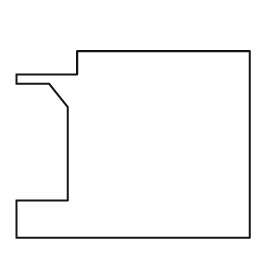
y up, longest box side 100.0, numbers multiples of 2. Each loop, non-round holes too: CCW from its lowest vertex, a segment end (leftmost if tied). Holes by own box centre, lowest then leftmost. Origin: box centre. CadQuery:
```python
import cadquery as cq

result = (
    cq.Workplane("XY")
    .moveTo(-50.0, -40.0)
    .lineTo(50.0, -40.0)
    .lineTo(50.0, 40.0)
    .lineTo(-24.0, 40.0)
    .lineTo(-24.0, 30.0)
    .lineTo(-50.0, 30.0)
    .lineTo(-50.0, 26.0)
    .lineTo(-36.0, 26.0)
    .lineTo(-28.0, 16.0)
    .lineTo(-28.0, -24.0)
    .lineTo(-50.0, -24.0)
    .close()
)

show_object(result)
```